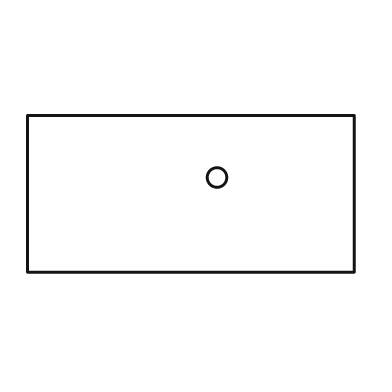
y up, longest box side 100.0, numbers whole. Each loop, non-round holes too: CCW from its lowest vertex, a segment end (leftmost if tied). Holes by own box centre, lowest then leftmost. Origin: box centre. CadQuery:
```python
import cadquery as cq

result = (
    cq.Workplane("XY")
    .moveTo(-50.0, -24.0)
    .lineTo(50.0, -24.0)
    .lineTo(50.0, 24.0)
    .lineTo(-50.0, 24.0)
    .close()
    .moveTo(8.0, 5.0)
    .circle(3.0)
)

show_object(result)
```